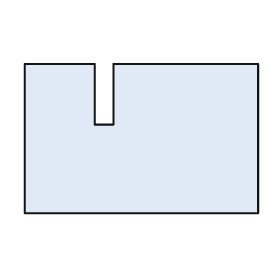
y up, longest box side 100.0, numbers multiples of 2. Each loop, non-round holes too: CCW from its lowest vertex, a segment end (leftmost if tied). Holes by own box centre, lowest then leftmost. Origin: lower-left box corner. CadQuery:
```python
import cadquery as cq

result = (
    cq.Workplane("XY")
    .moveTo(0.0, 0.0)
    .lineTo(100.0, 0.0)
    .lineTo(100.0, 64.0)
    .lineTo(38.0, 64.0)
    .lineTo(38.0, 38.0)
    .lineTo(30.0, 38.0)
    .lineTo(30.0, 64.0)
    .lineTo(0.0, 64.0)
    .close()
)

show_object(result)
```